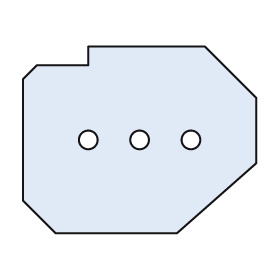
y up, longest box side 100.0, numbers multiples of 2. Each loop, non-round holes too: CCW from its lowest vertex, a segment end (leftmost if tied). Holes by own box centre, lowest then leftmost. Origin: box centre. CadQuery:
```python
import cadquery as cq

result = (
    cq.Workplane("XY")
    .moveTo(-36.0, -40.0)
    .lineTo(16.0, -40.0)
    .lineTo(50.0, -10.0)
    .lineTo(50.0, 18.0)
    .lineTo(28.0, 40.0)
    .lineTo(-22.0, 40.0)
    .lineTo(-22.0, 32.0)
    .lineTo(-44.0, 32.0)
    .lineTo(-50.0, 26.0)
    .lineTo(-50.0, -26.0)
    .close()
    .moveTo(-22.0, 0.0)
    .circle(4.0)
    .moveTo(0.0, 0.0)
    .circle(4.0)
    .moveTo(22.0, 0.0)
    .circle(4.0)
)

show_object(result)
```